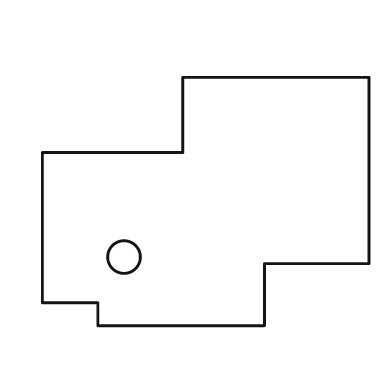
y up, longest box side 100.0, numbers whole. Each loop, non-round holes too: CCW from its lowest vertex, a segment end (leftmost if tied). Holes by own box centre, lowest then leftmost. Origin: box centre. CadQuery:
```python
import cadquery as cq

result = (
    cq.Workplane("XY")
    .moveTo(-33.0, -38.0)
    .lineTo(18.0, -38.0)
    .lineTo(18.0, -19.0)
    .lineTo(50.0, -19.0)
    .lineTo(50.0, 38.0)
    .lineTo(-7.0, 38.0)
    .lineTo(-7.0, 15.0)
    .lineTo(-50.0, 15.0)
    .lineTo(-50.0, -31.0)
    .lineTo(-33.0, -31.0)
    .close()
    .moveTo(-25.0, -17.0)
    .circle(5.0)
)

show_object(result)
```